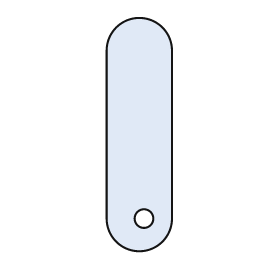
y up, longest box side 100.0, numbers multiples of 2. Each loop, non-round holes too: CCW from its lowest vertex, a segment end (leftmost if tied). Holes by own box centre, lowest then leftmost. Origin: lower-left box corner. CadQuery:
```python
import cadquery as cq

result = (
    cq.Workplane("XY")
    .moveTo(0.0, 14.0)
    .threePointArc((14.0, 0.0), (28.0, 14.0))
    .lineTo(28.0, 86.0)
    .threePointArc((14.0, 100.0), (0.0, 86.0))
    .close()
    .moveTo(16.0, 14.0)
    .circle(4.0)
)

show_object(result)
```